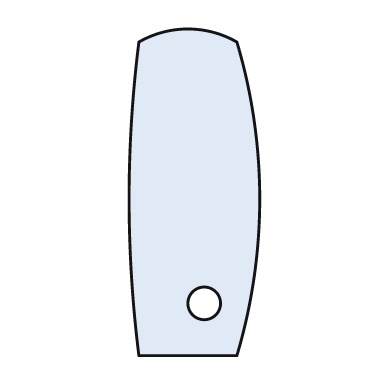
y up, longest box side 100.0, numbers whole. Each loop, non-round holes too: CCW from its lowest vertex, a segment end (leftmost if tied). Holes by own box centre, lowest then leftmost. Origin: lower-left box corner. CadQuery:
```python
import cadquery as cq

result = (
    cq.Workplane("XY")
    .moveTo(3.0, 0.0)
    .lineTo(33.0, 0.0)
    .threePointArc((40.0, 48.0), (33.0, 96.0))
    .threePointArc((18.0, 100.0), (3.0, 96.0))
    .threePointArc((0.0, 48.0), (3.0, 0.0))
    .close()
    .moveTo(23.0, 16.0)
    .circle(5.0)
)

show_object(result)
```